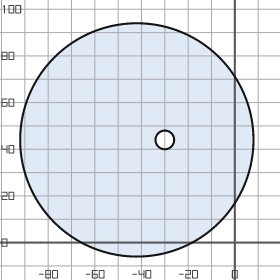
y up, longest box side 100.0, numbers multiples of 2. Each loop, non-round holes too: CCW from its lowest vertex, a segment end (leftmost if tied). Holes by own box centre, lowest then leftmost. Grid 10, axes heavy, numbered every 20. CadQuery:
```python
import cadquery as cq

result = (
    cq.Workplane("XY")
    .moveTo(-42.0, 44.0)
    .circle(50.0)
    .moveTo(-30.0, 44.0)
    .circle(4.0)
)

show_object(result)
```